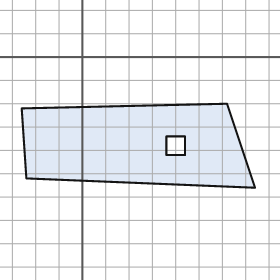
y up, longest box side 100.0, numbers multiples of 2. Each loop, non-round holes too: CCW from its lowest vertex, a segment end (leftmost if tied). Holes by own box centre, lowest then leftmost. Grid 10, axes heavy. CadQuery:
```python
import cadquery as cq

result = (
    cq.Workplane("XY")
    .moveTo(74.0, -56.0)
    .lineTo(62.0, -20.0)
    .lineTo(-26.0, -22.0)
    .lineTo(-24.0, -52.0)
    .close()
    .moveTo(36.0, -42.0)
    .lineTo(44.0, -42.0)
    .lineTo(44.0, -34.0)
    .lineTo(36.0, -34.0)
    .close()
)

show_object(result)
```